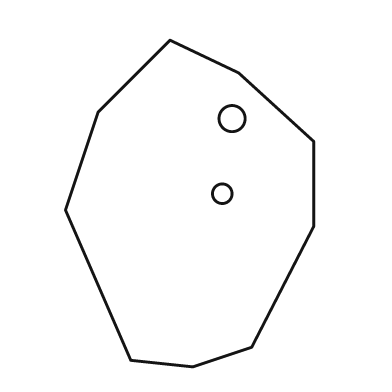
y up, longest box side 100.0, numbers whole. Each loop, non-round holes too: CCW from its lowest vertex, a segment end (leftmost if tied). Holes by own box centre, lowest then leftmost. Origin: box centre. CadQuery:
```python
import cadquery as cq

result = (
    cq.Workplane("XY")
    .moveTo(1.0, -50.0)
    .lineTo(19.0, -44.0)
    .lineTo(38.0, -7.0)
    .lineTo(38.0, 19.0)
    .lineTo(15.0, 40.0)
    .lineTo(-6.0, 50.0)
    .lineTo(-28.0, 28.0)
    .lineTo(-38.0, -2.0)
    .lineTo(-18.0, -48.0)
    .close()
    .moveTo(10.0, 3.0)
    .circle(3.0)
    .moveTo(13.0, 26.0)
    .circle(4.0)
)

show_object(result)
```